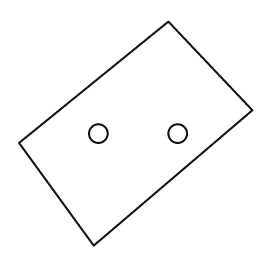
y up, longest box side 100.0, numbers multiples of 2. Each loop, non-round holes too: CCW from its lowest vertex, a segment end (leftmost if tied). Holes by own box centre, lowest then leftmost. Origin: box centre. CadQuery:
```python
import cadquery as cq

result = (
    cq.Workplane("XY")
    .moveTo(-18.0, -48.0)
    .lineTo(50.0, 10.0)
    .lineTo(14.0, 48.0)
    .lineTo(-50.0, -4.0)
    .close()
    .moveTo(-16.0, 0.0)
    .circle(4.0)
    .moveTo(18.0, 0.0)
    .circle(4.0)
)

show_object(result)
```